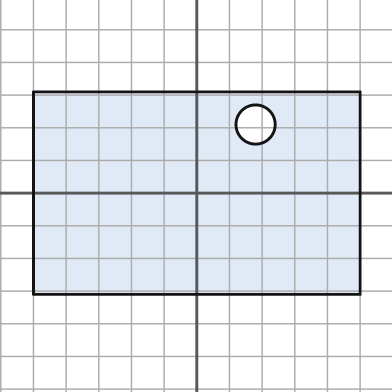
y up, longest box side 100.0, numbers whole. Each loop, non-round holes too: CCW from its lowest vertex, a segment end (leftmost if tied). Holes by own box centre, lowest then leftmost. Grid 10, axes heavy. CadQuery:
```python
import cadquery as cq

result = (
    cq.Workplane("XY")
    .moveTo(-50.0, -31.0)
    .lineTo(50.0, -31.0)
    .lineTo(50.0, 31.0)
    .lineTo(-50.0, 31.0)
    .close()
    .moveTo(18.0, 21.0)
    .circle(6.0)
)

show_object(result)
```